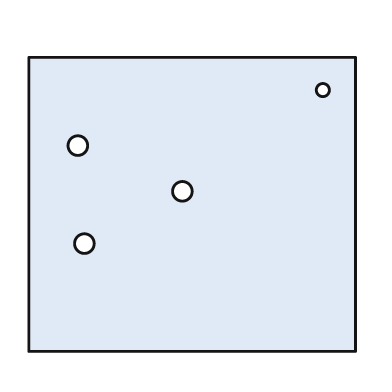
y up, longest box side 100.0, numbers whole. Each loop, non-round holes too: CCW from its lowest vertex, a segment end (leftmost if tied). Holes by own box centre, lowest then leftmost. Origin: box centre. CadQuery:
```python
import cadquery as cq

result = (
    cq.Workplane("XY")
    .moveTo(-50.0, -45.0)
    .lineTo(50.0, -45.0)
    .lineTo(50.0, 45.0)
    .lineTo(-50.0, 45.0)
    .close()
    .moveTo(-33.0, -12.0)
    .circle(3.0)
    .moveTo(-3.0, 4.0)
    .circle(3.0)
    .moveTo(-35.0, 18.0)
    .circle(3.0)
    .moveTo(40.0, 35.0)
    .circle(2.0)
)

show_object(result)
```